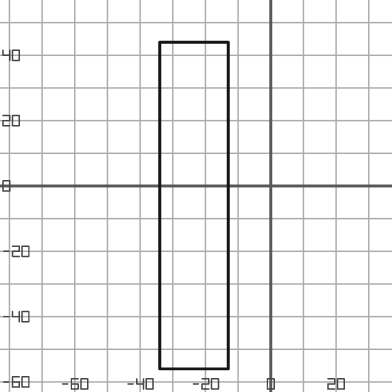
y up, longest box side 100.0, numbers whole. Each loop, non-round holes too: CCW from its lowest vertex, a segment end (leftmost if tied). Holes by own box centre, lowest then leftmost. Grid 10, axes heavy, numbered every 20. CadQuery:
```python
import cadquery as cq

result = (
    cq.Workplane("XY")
    .moveTo(-34.0, -56.0)
    .lineTo(-13.0, -56.0)
    .lineTo(-13.0, 44.0)
    .lineTo(-34.0, 44.0)
    .close()
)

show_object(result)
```